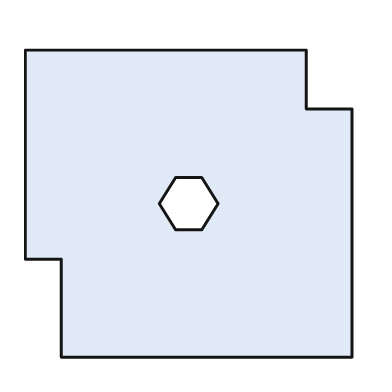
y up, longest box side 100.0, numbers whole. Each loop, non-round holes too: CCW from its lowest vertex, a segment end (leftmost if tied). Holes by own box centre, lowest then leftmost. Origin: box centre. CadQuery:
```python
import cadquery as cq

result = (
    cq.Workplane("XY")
    .moveTo(-39.0, -47.0)
    .lineTo(50.0, -47.0)
    .lineTo(50.0, 29.0)
    .lineTo(36.0, 29.0)
    .lineTo(36.0, 47.0)
    .lineTo(-50.0, 47.0)
    .lineTo(-50.0, -17.0)
    .lineTo(-39.0, -17.0)
    .close()
    .moveTo(-4.0, -8.0)
    .lineTo(4.0, -8.0)
    .lineTo(9.0, 0.0)
    .lineTo(4.0, 8.0)
    .lineTo(-4.0, 8.0)
    .lineTo(-9.0, 0.0)
    .close()
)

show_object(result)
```